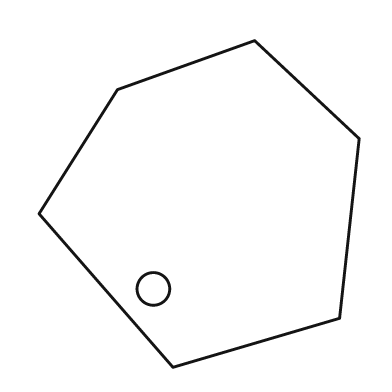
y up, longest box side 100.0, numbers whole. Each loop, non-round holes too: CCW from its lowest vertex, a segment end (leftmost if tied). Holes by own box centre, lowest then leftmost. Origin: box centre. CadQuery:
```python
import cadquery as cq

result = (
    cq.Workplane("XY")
    .moveTo(-8.0, -50.0)
    .lineTo(43.0, -35.0)
    .lineTo(49.0, 20.0)
    .lineTo(17.0, 50.0)
    .lineTo(-25.0, 35.0)
    .lineTo(-49.0, -3.0)
    .close()
    .moveTo(-14.0, -26.0)
    .circle(5.0)
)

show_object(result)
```